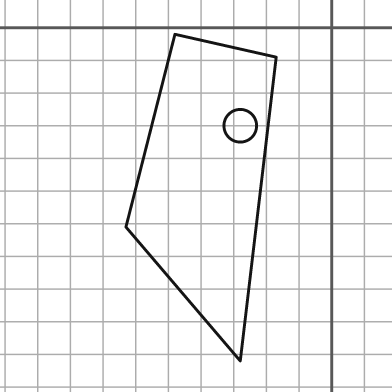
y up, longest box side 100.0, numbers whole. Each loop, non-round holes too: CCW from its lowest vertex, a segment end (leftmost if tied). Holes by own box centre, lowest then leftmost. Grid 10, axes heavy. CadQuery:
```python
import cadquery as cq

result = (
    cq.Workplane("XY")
    .moveTo(-28.0, -102.0)
    .lineTo(-17.0, -9.0)
    .lineTo(-48.0, -2.0)
    .lineTo(-63.0, -61.0)
    .close()
    .moveTo(-28.0, -30.0)
    .circle(5.0)
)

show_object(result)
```